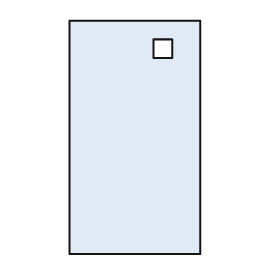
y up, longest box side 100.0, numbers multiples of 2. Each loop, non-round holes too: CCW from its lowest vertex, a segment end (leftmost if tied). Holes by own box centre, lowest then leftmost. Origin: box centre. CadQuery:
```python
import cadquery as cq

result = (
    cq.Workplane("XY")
    .moveTo(-28.0, -50.0)
    .lineTo(28.0, -50.0)
    .lineTo(28.0, 50.0)
    .lineTo(-28.0, 50.0)
    .close()
    .moveTo(8.0, 34.0)
    .lineTo(16.0, 34.0)
    .lineTo(16.0, 42.0)
    .lineTo(8.0, 42.0)
    .close()
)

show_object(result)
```